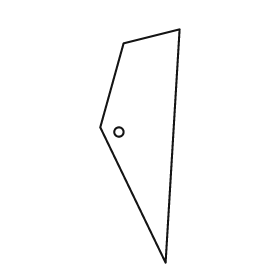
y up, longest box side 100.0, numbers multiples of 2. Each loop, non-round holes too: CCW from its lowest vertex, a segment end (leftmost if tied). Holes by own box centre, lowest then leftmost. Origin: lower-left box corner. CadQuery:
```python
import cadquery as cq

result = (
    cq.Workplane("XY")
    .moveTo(28.0, 0.0)
    .lineTo(34.0, 100.0)
    .lineTo(10.0, 94.0)
    .lineTo(0.0, 58.0)
    .close()
    .moveTo(8.0, 56.0)
    .circle(2.0)
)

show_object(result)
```